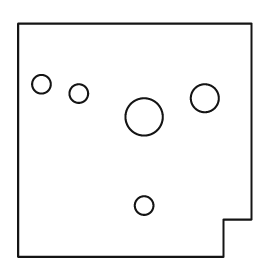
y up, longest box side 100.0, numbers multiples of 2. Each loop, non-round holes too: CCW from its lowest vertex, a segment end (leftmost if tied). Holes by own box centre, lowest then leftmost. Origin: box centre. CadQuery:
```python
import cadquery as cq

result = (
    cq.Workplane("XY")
    .moveTo(-50.0, -50.0)
    .lineTo(38.0, -50.0)
    .lineTo(38.0, -34.0)
    .lineTo(50.0, -34.0)
    .lineTo(50.0, 50.0)
    .lineTo(-50.0, 50.0)
    .close()
    .moveTo(4.0, -28.0)
    .circle(4.0)
    .moveTo(4.0, 10.0)
    .circle(8.0)
    .moveTo(30.0, 18.0)
    .circle(6.0)
    .moveTo(-24.0, 20.0)
    .circle(4.0)
    .moveTo(-40.0, 24.0)
    .circle(4.0)
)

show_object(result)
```